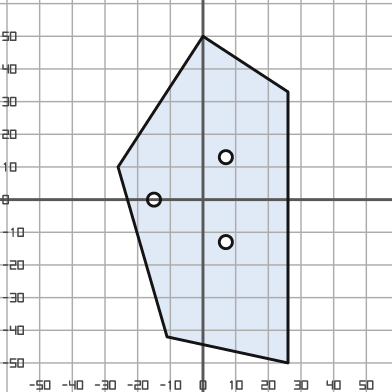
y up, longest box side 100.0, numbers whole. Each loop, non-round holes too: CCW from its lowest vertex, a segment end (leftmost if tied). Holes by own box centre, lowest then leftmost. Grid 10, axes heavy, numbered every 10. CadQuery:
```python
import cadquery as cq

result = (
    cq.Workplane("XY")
    .moveTo(26.0, -50.0)
    .lineTo(26.0, 33.0)
    .lineTo(0.0, 50.0)
    .lineTo(-26.0, 10.0)
    .lineTo(-11.0, -42.0)
    .close()
    .moveTo(7.0, -13.0)
    .circle(2.0)
    .moveTo(-15.0, 0.0)
    .circle(2.0)
    .moveTo(7.0, 13.0)
    .circle(2.0)
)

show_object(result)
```